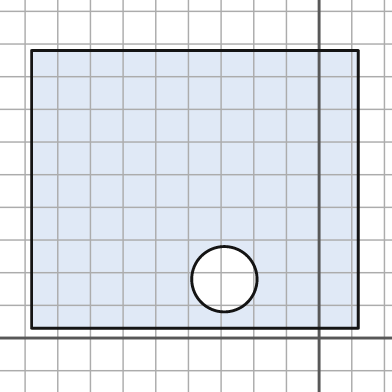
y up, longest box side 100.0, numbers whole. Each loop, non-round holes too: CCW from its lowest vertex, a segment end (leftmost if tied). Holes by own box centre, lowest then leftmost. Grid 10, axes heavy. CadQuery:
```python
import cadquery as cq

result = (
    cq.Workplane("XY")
    .moveTo(-88.0, 3.0)
    .lineTo(12.0, 3.0)
    .lineTo(12.0, 88.0)
    .lineTo(-88.0, 88.0)
    .close()
    .moveTo(-29.0, 18.0)
    .circle(10.0)
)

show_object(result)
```